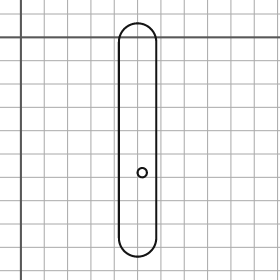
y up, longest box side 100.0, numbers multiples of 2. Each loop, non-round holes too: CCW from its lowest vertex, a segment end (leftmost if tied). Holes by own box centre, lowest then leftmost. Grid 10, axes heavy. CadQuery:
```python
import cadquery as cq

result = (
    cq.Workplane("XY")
    .moveTo(42.0, -86.0)
    .threePointArc((50.0, -94.0), (58.0, -86.0))
    .lineTo(58.0, -2.0)
    .threePointArc((50.0, 6.0), (42.0, -2.0))
    .close()
    .moveTo(52.0, -58.0)
    .circle(2.0)
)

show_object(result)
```